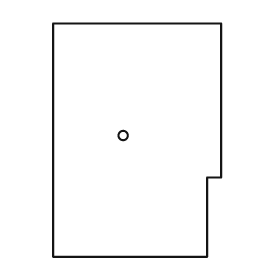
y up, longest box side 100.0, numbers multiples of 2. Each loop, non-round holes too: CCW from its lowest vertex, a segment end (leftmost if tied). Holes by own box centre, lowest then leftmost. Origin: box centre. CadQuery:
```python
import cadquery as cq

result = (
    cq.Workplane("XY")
    .moveTo(-36.0, -50.0)
    .lineTo(30.0, -50.0)
    .lineTo(30.0, -16.0)
    .lineTo(36.0, -16.0)
    .lineTo(36.0, 50.0)
    .lineTo(-36.0, 50.0)
    .close()
    .moveTo(-6.0, 2.0)
    .circle(2.0)
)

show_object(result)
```